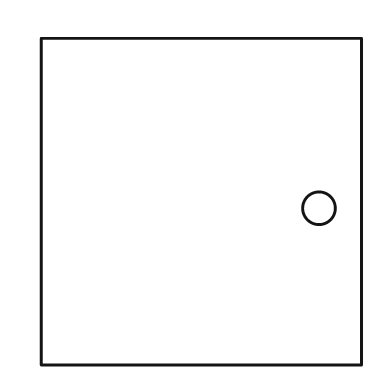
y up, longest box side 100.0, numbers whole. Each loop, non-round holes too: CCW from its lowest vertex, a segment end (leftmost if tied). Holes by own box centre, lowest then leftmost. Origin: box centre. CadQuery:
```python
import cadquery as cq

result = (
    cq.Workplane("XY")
    .moveTo(-49.0, -50.0)
    .lineTo(49.0, -50.0)
    .lineTo(49.0, 50.0)
    .lineTo(-49.0, 50.0)
    .close()
    .moveTo(36.0, -2.0)
    .circle(5.0)
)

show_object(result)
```